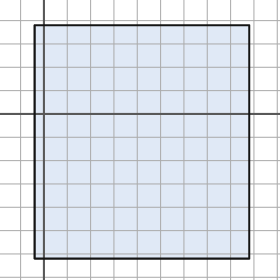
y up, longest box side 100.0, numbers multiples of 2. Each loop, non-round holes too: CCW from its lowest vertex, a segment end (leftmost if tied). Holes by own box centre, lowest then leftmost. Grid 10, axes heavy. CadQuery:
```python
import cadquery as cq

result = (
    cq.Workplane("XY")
    .moveTo(-4.0, -62.0)
    .lineTo(88.0, -62.0)
    .lineTo(88.0, 38.0)
    .lineTo(-4.0, 38.0)
    .close()
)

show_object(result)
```